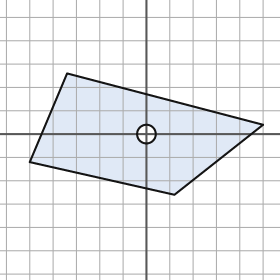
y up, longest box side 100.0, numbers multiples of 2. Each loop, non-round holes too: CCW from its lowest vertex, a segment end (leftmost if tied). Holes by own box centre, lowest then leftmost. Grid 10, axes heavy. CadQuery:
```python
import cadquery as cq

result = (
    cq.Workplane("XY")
    .moveTo(12.0, -26.0)
    .lineTo(50.0, 4.0)
    .lineTo(-34.0, 26.0)
    .lineTo(-50.0, -12.0)
    .close()
    .moveTo(0.0, 0.0)
    .circle(4.0)
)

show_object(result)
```